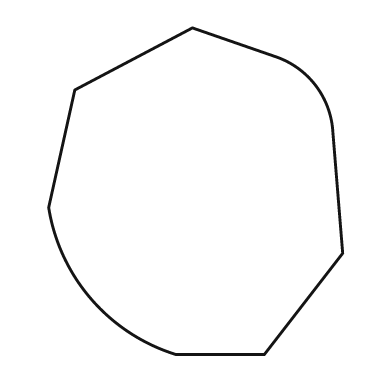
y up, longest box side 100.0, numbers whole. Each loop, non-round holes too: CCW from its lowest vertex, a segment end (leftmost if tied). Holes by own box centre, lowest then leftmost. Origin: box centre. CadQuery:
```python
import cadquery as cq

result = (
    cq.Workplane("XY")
    .moveTo(-6.0, -50.0)
    .lineTo(21.0, -50.0)
    .lineTo(45.0, -19.0)
    .lineTo(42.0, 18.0)
    .threePointArc((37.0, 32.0), (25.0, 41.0))
    .lineTo(-1.0, 50.0)
    .lineTo(-37.0, 31.0)
    .lineTo(-45.0, -5.0)
    .threePointArc((-32.0, -33.0), (-6.0, -50.0))
    .close()
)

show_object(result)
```